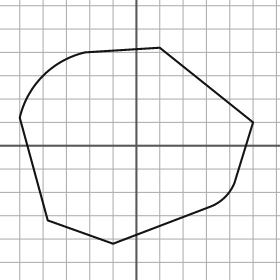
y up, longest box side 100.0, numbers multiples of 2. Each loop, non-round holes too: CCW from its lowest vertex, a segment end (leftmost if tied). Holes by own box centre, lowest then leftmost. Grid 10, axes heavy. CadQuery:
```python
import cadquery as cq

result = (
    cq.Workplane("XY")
    .moveTo(-10.0, -42.0)
    .lineTo(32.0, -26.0)
    .threePointArc((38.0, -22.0), (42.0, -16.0))
    .lineTo(50.0, 10.0)
    .lineTo(10.0, 42.0)
    .lineTo(-22.0, 40.0)
    .threePointArc((-40.0, 30.0), (-50.0, 12.0))
    .lineTo(-38.0, -32.0)
    .close()
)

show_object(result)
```